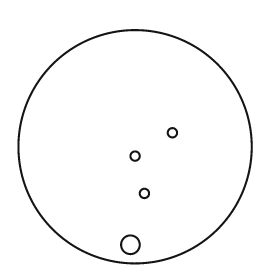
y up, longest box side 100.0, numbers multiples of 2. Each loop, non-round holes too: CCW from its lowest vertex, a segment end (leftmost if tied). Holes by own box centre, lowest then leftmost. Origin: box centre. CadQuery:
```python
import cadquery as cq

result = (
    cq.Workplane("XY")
    .moveTo(0.0, 0.0)
    .circle(50.0)
    .moveTo(-2.0, -42.0)
    .circle(4.0)
    .moveTo(4.0, -20.0)
    .circle(2.0)
    .moveTo(0.0, -4.0)
    .circle(2.0)
    .moveTo(16.0, 6.0)
    .circle(2.0)
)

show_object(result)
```